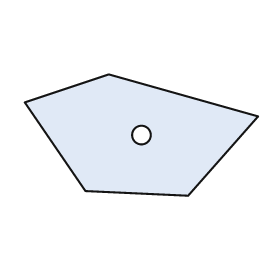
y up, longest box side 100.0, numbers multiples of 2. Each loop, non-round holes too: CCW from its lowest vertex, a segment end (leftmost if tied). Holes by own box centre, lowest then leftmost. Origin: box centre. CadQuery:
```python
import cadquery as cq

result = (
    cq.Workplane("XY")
    .moveTo(20.0, -26.0)
    .lineTo(50.0, 8.0)
    .lineTo(-14.0, 26.0)
    .lineTo(-50.0, 14.0)
    .lineTo(-24.0, -24.0)
    .close()
    .moveTo(0.0, 0.0)
    .circle(4.0)
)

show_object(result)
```